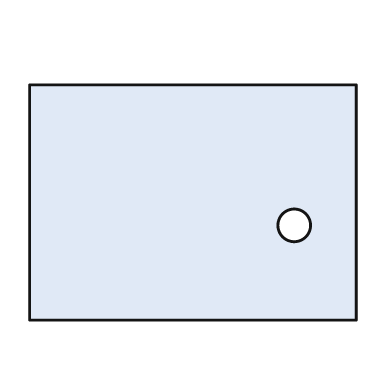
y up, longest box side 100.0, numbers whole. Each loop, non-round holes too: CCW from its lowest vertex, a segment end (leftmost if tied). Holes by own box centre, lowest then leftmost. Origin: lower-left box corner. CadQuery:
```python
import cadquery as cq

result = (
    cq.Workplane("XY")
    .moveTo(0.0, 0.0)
    .lineTo(100.0, 0.0)
    .lineTo(100.0, 72.0)
    .lineTo(0.0, 72.0)
    .close()
    .moveTo(81.0, 29.0)
    .circle(5.0)
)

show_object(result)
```